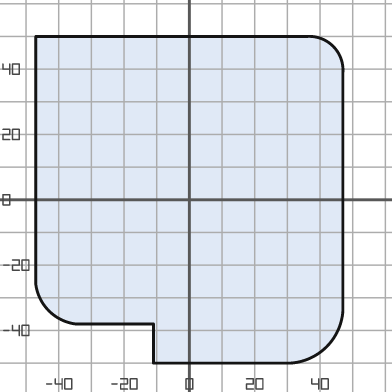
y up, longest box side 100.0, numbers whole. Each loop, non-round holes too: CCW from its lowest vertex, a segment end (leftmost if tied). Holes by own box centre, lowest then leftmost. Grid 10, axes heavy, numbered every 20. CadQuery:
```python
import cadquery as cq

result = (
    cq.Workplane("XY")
    .moveTo(-11.0, -50.0)
    .lineTo(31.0, -50.0)
    .threePointArc((42.0, -45.0), (47.0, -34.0))
    .lineTo(47.0, 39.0)
    .threePointArc((44.0, 47.0), (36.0, 50.0))
    .lineTo(-47.0, 50.0)
    .lineTo(-47.0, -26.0)
    .threePointArc((-43.0, -34.0), (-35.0, -38.0))
    .lineTo(-11.0, -38.0)
    .close()
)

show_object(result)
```